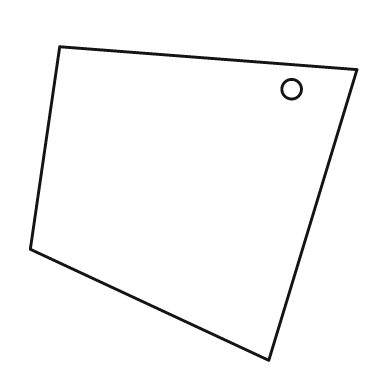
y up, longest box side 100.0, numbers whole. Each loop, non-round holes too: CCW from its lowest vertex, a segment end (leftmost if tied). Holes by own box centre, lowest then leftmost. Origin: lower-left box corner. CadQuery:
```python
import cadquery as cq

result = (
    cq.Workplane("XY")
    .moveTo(73.0, 0.0)
    .lineTo(100.0, 89.0)
    .lineTo(9.0, 96.0)
    .lineTo(0.0, 34.0)
    .close()
    .moveTo(80.0, 83.0)
    .circle(3.0)
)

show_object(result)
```